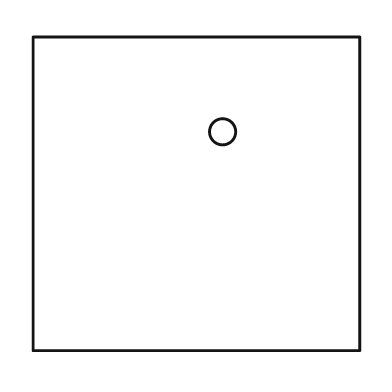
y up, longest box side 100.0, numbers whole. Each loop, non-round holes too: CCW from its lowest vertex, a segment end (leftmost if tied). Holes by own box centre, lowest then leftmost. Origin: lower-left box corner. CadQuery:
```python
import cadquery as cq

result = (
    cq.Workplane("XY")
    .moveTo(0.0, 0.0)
    .lineTo(100.0, 0.0)
    .lineTo(100.0, 96.0)
    .lineTo(0.0, 96.0)
    .close()
    .moveTo(58.0, 67.0)
    .circle(4.0)
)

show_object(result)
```